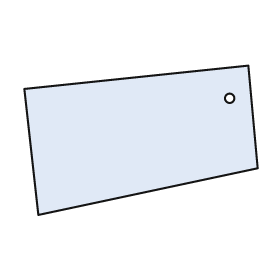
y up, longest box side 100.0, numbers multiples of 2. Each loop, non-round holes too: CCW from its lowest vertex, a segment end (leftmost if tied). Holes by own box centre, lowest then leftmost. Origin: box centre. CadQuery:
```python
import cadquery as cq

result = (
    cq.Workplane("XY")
    .moveTo(-44.0, -32.0)
    .lineTo(50.0, -12.0)
    .lineTo(46.0, 32.0)
    .lineTo(-50.0, 22.0)
    .close()
    .moveTo(38.0, 18.0)
    .circle(2.0)
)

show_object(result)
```